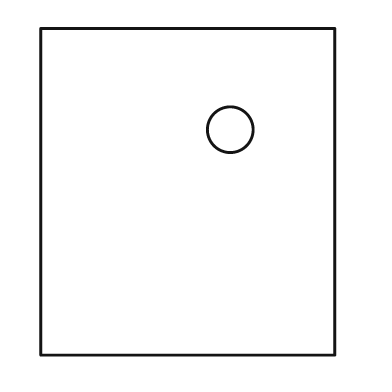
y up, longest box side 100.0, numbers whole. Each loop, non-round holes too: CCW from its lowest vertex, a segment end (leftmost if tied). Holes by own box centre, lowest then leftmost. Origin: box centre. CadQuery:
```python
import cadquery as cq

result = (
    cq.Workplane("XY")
    .moveTo(-45.0, -50.0)
    .lineTo(45.0, -50.0)
    .lineTo(45.0, 50.0)
    .lineTo(-45.0, 50.0)
    .close()
    .moveTo(13.0, 19.0)
    .circle(7.0)
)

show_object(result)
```